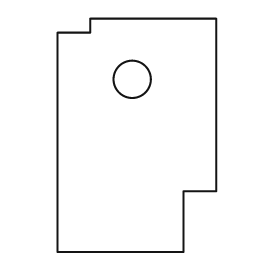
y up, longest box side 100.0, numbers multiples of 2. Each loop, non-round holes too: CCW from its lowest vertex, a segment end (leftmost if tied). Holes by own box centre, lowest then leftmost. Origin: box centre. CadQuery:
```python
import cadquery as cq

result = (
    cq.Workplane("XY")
    .moveTo(-34.0, -50.0)
    .lineTo(20.0, -50.0)
    .lineTo(20.0, -24.0)
    .lineTo(34.0, -24.0)
    .lineTo(34.0, 50.0)
    .lineTo(-20.0, 50.0)
    .lineTo(-20.0, 44.0)
    .lineTo(-34.0, 44.0)
    .close()
    .moveTo(-2.0, 24.0)
    .circle(8.0)
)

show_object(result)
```